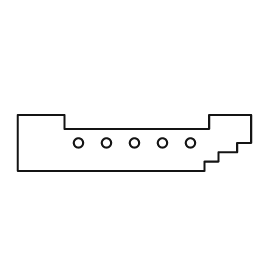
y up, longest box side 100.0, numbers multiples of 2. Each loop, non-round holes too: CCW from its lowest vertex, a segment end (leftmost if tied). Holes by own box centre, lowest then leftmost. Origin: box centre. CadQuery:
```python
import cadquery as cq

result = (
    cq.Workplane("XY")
    .moveTo(-50.0, -12.0)
    .lineTo(30.0, -12.0)
    .lineTo(30.0, -8.0)
    .lineTo(36.0, -8.0)
    .lineTo(36.0, -4.0)
    .lineTo(44.0, -4.0)
    .lineTo(44.0, 0.0)
    .lineTo(50.0, 0.0)
    .lineTo(50.0, 12.0)
    .lineTo(32.0, 12.0)
    .lineTo(32.0, 6.0)
    .lineTo(-30.0, 6.0)
    .lineTo(-30.0, 12.0)
    .lineTo(-50.0, 12.0)
    .close()
    .moveTo(-24.0, 0.0)
    .circle(2.0)
    .moveTo(-12.0, 0.0)
    .circle(2.0)
    .moveTo(0.0, 0.0)
    .circle(2.0)
    .moveTo(12.0, 0.0)
    .circle(2.0)
    .moveTo(24.0, 0.0)
    .circle(2.0)
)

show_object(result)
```